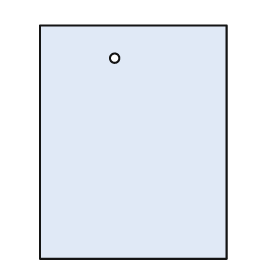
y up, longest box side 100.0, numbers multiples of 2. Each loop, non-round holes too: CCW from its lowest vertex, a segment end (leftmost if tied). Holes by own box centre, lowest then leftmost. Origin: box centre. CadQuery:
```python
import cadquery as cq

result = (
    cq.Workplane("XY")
    .moveTo(-40.0, -50.0)
    .lineTo(40.0, -50.0)
    .lineTo(40.0, 50.0)
    .lineTo(-40.0, 50.0)
    .close()
    .moveTo(-8.0, 36.0)
    .circle(2.0)
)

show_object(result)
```